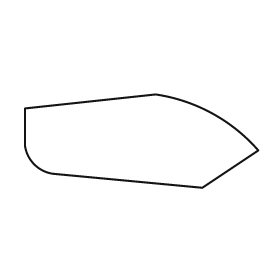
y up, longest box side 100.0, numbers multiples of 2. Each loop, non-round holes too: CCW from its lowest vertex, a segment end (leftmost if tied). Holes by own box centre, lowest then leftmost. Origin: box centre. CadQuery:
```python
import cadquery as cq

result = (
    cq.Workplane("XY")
    .moveTo(26.0, -20.0)
    .lineTo(50.0, -4.0)
    .threePointArc((30.0, 12.0), (6.0, 20.0))
    .lineTo(-50.0, 14.0)
    .lineTo(-50.0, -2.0)
    .threePointArc((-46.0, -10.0), (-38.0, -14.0))
    .close()
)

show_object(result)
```